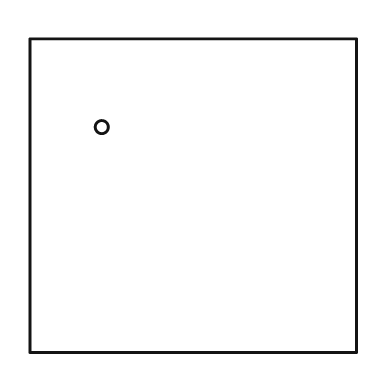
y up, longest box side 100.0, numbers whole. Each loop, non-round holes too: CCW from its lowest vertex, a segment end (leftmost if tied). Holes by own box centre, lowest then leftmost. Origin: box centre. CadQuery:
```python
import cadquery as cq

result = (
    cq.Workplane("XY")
    .moveTo(-50.0, -48.0)
    .lineTo(50.0, -48.0)
    .lineTo(50.0, 48.0)
    .lineTo(-50.0, 48.0)
    .close()
    .moveTo(-28.0, 21.0)
    .circle(2.0)
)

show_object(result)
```